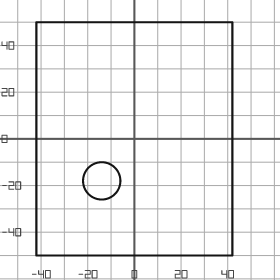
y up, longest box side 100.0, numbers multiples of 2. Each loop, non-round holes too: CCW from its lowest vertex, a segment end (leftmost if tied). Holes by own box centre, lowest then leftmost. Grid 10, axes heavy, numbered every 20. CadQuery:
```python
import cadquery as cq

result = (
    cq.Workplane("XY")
    .moveTo(-42.0, -50.0)
    .lineTo(42.0, -50.0)
    .lineTo(42.0, 50.0)
    .lineTo(-42.0, 50.0)
    .close()
    .moveTo(-14.0, -18.0)
    .circle(8.0)
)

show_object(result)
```